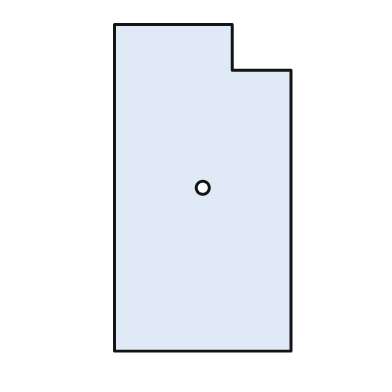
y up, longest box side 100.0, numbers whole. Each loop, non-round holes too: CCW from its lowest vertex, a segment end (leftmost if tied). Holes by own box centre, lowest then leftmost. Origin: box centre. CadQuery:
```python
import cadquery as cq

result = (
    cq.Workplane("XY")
    .moveTo(-27.0, -50.0)
    .lineTo(27.0, -50.0)
    .lineTo(27.0, 36.0)
    .lineTo(9.0, 36.0)
    .lineTo(9.0, 50.0)
    .lineTo(-27.0, 50.0)
    .close()
    .moveTo(0.0, 0.0)
    .circle(2.0)
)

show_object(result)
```